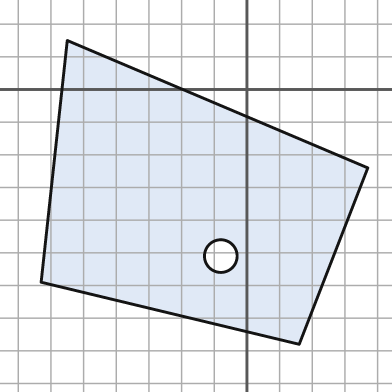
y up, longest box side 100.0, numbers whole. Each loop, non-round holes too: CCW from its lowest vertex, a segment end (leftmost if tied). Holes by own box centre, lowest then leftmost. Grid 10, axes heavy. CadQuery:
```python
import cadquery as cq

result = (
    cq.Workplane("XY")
    .moveTo(16.0, -78.0)
    .lineTo(37.0, -24.0)
    .lineTo(-55.0, 15.0)
    .lineTo(-63.0, -59.0)
    .close()
    .moveTo(-8.0, -51.0)
    .circle(5.0)
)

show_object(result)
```